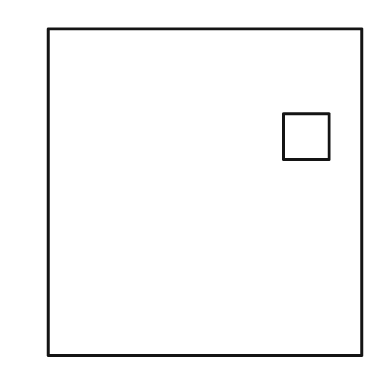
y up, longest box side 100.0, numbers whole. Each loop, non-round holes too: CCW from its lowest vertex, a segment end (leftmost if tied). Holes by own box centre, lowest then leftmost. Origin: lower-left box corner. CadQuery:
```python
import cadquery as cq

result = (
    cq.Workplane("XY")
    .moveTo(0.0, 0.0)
    .lineTo(96.0, 0.0)
    .lineTo(96.0, 100.0)
    .lineTo(0.0, 100.0)
    .close()
    .moveTo(72.0, 60.0)
    .lineTo(86.0, 60.0)
    .lineTo(86.0, 74.0)
    .lineTo(72.0, 74.0)
    .close()
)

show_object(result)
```